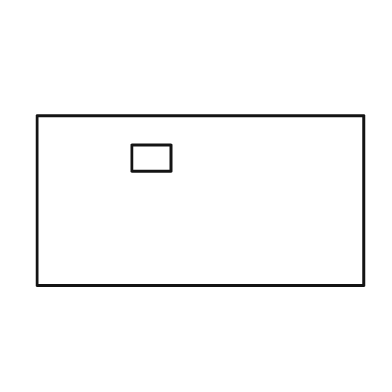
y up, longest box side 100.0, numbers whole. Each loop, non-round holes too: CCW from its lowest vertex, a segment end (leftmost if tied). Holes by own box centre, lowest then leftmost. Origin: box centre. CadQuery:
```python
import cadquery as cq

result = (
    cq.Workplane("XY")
    .moveTo(-50.0, -26.0)
    .lineTo(50.0, -26.0)
    .lineTo(50.0, 26.0)
    .lineTo(-50.0, 26.0)
    .close()
    .moveTo(-21.0, 9.0)
    .lineTo(-9.0, 9.0)
    .lineTo(-9.0, 17.0)
    .lineTo(-21.0, 17.0)
    .close()
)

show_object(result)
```